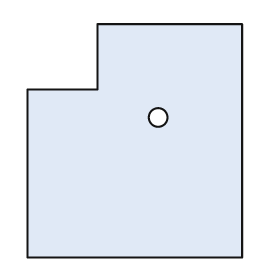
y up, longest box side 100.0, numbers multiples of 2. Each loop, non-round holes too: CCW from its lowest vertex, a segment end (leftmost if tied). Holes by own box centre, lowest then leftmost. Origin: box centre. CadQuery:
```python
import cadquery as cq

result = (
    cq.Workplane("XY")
    .moveTo(-46.0, -50.0)
    .lineTo(46.0, -50.0)
    .lineTo(46.0, 50.0)
    .lineTo(-16.0, 50.0)
    .lineTo(-16.0, 22.0)
    .lineTo(-46.0, 22.0)
    .close()
    .moveTo(10.0, 10.0)
    .circle(4.0)
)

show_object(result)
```